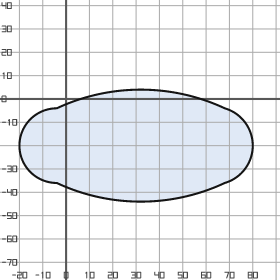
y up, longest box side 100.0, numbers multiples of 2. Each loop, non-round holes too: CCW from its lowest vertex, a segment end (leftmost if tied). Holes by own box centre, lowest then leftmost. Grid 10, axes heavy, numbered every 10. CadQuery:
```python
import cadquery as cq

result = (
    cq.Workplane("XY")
    .moveTo(-4.0, -36.0)
    .threePointArc((32.0, -44.0), (68.0, -36.0))
    .threePointArc((80.0, -20.0), (68.0, -4.0))
    .threePointArc((32.0, 4.0), (-4.0, -4.0))
    .threePointArc((-20.0, -20.0), (-4.0, -36.0))
    .close()
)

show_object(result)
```